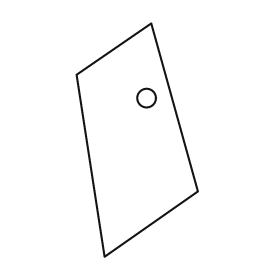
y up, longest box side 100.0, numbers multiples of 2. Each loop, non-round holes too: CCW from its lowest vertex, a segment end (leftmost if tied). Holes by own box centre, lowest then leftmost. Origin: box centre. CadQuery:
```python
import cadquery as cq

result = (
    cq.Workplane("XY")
    .moveTo(-14.0, -50.0)
    .lineTo(26.0, -22.0)
    .lineTo(6.0, 50.0)
    .lineTo(-26.0, 28.0)
    .close()
    .moveTo(4.0, 18.0)
    .circle(4.0)
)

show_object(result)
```